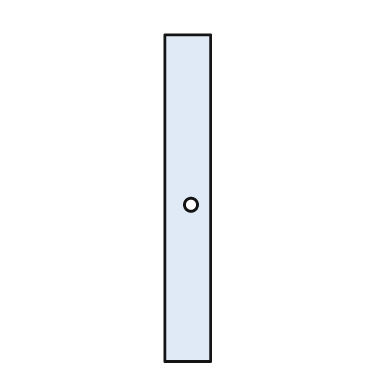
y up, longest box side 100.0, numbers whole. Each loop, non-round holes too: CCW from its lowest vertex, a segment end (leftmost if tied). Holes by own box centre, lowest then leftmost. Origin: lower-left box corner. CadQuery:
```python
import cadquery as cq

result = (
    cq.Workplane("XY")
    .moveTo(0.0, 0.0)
    .lineTo(14.0, 0.0)
    .lineTo(14.0, 100.0)
    .lineTo(0.0, 100.0)
    .close()
    .moveTo(8.0, 48.0)
    .circle(2.0)
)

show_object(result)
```